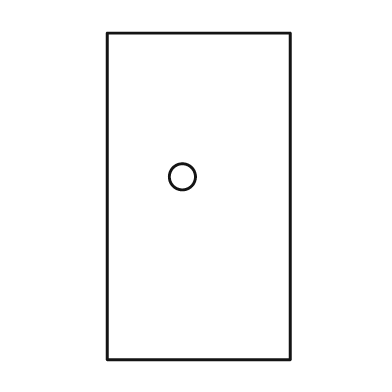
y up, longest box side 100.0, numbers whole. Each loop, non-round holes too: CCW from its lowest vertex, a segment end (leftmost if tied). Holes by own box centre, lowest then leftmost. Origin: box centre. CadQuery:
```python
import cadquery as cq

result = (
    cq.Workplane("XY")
    .moveTo(-28.0, -50.0)
    .lineTo(28.0, -50.0)
    .lineTo(28.0, 50.0)
    .lineTo(-28.0, 50.0)
    .close()
    .moveTo(-5.0, 6.0)
    .circle(4.0)
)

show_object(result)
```